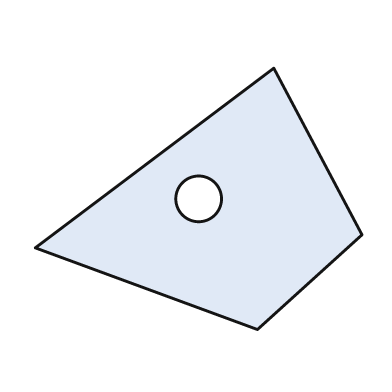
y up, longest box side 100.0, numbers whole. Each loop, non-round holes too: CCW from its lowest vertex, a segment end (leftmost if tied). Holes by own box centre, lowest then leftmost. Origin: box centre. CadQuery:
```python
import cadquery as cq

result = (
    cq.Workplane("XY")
    .moveTo(18.0, -40.0)
    .lineTo(50.0, -11.0)
    .lineTo(23.0, 40.0)
    .lineTo(-50.0, -15.0)
    .close()
    .moveTo(0.0, 0.0)
    .circle(7.0)
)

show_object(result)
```